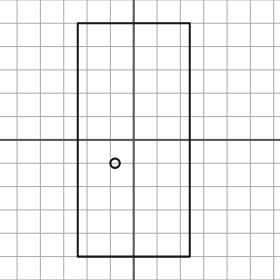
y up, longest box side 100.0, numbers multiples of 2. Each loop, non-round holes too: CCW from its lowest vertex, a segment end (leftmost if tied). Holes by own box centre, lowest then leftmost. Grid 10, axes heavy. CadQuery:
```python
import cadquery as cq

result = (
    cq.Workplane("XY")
    .moveTo(-24.0, -50.0)
    .lineTo(24.0, -50.0)
    .lineTo(24.0, 50.0)
    .lineTo(-24.0, 50.0)
    .close()
    .moveTo(-8.0, -10.0)
    .circle(2.0)
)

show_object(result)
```